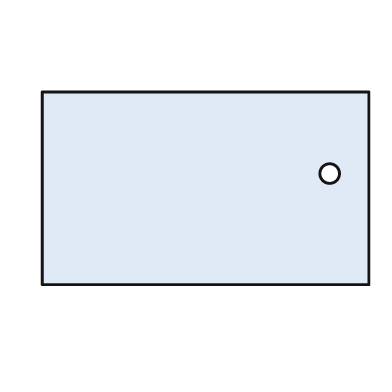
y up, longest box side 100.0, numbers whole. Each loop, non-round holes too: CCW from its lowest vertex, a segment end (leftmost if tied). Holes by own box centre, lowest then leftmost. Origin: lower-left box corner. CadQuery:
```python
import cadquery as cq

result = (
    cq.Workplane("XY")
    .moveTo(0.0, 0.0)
    .lineTo(100.0, 0.0)
    .lineTo(100.0, 59.0)
    .lineTo(0.0, 59.0)
    .close()
    .moveTo(88.0, 34.0)
    .circle(3.0)
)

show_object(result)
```